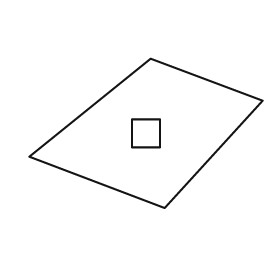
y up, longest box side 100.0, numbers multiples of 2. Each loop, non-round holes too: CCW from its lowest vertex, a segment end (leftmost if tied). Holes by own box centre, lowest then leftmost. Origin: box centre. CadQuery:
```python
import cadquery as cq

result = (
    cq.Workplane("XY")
    .moveTo(8.0, -32.0)
    .lineTo(50.0, 14.0)
    .lineTo(2.0, 32.0)
    .lineTo(-50.0, -10.0)
    .close()
    .moveTo(-6.0, -6.0)
    .lineTo(6.0, -6.0)
    .lineTo(6.0, 6.0)
    .lineTo(-6.0, 6.0)
    .close()
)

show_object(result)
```